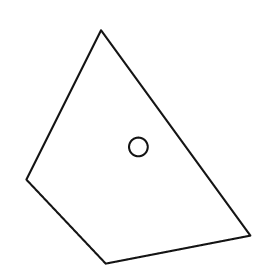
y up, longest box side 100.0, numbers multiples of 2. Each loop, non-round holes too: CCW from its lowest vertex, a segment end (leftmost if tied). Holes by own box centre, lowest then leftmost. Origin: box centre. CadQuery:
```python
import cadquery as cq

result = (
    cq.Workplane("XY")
    .moveTo(-14.0, -50.0)
    .lineTo(48.0, -38.0)
    .lineTo(-16.0, 50.0)
    .lineTo(-48.0, -14.0)
    .close()
    .moveTo(0.0, 0.0)
    .circle(4.0)
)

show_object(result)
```